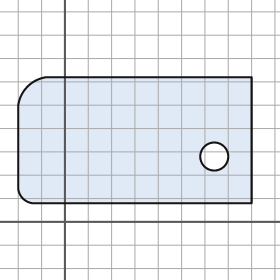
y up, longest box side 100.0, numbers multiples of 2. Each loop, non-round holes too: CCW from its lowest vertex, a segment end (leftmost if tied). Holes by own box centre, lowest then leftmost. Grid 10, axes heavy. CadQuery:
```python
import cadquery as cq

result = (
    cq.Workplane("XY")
    .moveTo(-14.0, 8.0)
    .lineTo(80.0, 8.0)
    .lineTo(80.0, 62.0)
    .lineTo(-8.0, 62.0)
    .threePointArc((-16.0, 58.0), (-20.0, 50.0))
    .lineTo(-20.0, 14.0)
    .threePointArc((-18.0, 10.0), (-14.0, 8.0))
    .close()
    .moveTo(64.0, 28.0)
    .circle(6.0)
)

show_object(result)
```